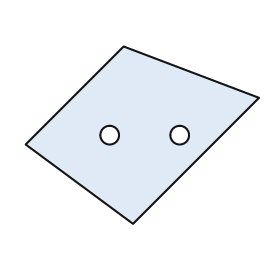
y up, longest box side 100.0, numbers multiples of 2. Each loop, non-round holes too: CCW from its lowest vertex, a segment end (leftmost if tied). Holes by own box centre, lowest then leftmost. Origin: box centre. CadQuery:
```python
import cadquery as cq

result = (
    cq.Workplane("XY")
    .moveTo(-4.0, -38.0)
    .lineTo(50.0, 16.0)
    .lineTo(-8.0, 38.0)
    .lineTo(-50.0, -4.0)
    .close()
    .moveTo(-14.0, 0.0)
    .circle(4.0)
    .moveTo(16.0, 0.0)
    .circle(4.0)
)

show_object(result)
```